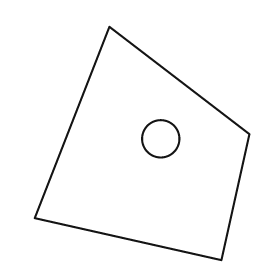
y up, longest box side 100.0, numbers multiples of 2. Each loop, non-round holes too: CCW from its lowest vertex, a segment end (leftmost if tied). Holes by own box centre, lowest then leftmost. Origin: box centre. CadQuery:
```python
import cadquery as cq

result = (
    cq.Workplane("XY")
    .moveTo(34.0, -50.0)
    .lineTo(46.0, 4.0)
    .lineTo(-14.0, 50.0)
    .lineTo(-46.0, -32.0)
    .close()
    .moveTo(8.0, 2.0)
    .circle(8.0)
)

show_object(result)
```